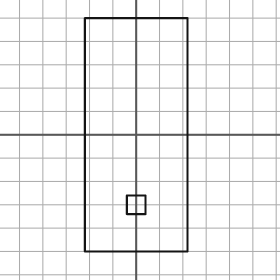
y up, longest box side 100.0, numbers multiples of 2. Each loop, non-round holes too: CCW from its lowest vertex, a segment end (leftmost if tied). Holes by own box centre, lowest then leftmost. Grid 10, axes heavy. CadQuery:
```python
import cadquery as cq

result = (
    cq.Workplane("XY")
    .moveTo(-22.0, -50.0)
    .lineTo(22.0, -50.0)
    .lineTo(22.0, 50.0)
    .lineTo(-22.0, 50.0)
    .close()
    .moveTo(-4.0, -34.0)
    .lineTo(4.0, -34.0)
    .lineTo(4.0, -26.0)
    .lineTo(-4.0, -26.0)
    .close()
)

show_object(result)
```